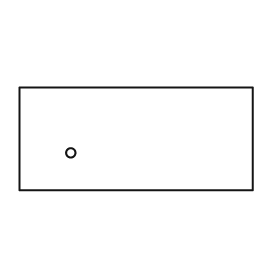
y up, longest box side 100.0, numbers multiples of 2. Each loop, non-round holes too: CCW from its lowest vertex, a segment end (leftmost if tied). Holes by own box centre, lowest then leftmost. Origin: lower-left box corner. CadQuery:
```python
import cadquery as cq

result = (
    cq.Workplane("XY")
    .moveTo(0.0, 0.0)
    .lineTo(100.0, 0.0)
    .lineTo(100.0, 44.0)
    .lineTo(0.0, 44.0)
    .close()
    .moveTo(22.0, 16.0)
    .circle(2.0)
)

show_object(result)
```